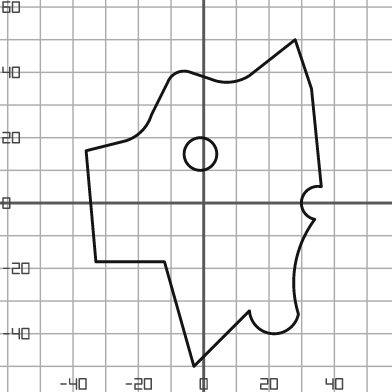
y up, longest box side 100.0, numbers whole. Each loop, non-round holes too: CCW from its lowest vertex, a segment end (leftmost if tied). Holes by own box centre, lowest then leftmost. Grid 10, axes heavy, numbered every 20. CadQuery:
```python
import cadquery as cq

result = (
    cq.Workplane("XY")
    .moveTo(-3.0, -50.0)
    .lineTo(14.0, -33.0)
    .threePointArc((21.0, -40.0), (29.0, -34.0))
    .threePointArc((28.0, -19.0), (34.0, -5.0))
    .threePointArc((30.0, 1.0), (36.0, 5.0))
    .lineTo(33.0, 35.0)
    .lineTo(28.0, 50.0)
    .lineTo(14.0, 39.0)
    .threePointArc((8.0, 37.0), (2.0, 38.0))
    .lineTo(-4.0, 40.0)
    .threePointArc((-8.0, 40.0), (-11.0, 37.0))
    .lineTo(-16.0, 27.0)
    .threePointArc((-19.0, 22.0), (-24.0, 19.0))
    .lineTo(-36.0, 16.0)
    .lineTo(-33.0, -18.0)
    .lineTo(-12.0, -18.0)
    .close()
    .moveTo(-1.0, 15.0)
    .circle(5.0)
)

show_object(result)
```